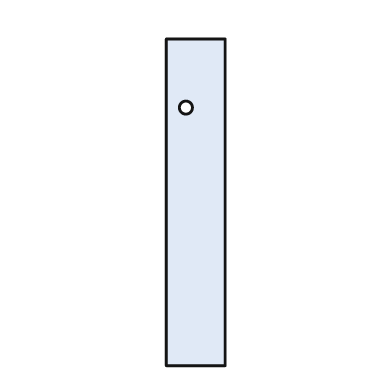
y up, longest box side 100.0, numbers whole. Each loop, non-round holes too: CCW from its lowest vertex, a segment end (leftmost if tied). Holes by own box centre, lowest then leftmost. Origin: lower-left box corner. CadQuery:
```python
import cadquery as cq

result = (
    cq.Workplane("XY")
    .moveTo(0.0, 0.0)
    .lineTo(18.0, 0.0)
    .lineTo(18.0, 100.0)
    .lineTo(0.0, 100.0)
    .close()
    .moveTo(6.0, 79.0)
    .circle(2.0)
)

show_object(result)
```